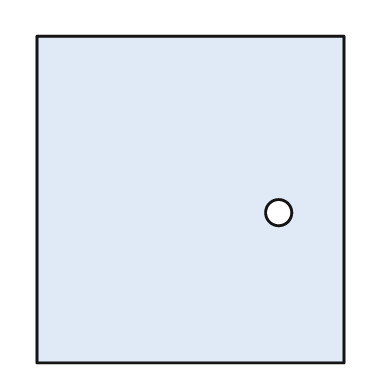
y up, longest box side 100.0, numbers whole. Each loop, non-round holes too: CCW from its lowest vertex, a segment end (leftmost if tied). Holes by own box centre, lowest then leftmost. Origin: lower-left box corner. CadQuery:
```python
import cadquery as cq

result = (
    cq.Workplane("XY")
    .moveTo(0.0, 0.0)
    .lineTo(94.0, 0.0)
    .lineTo(94.0, 100.0)
    .lineTo(0.0, 100.0)
    .close()
    .moveTo(74.0, 46.0)
    .circle(4.0)
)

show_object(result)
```